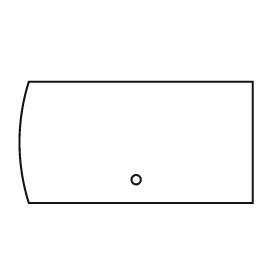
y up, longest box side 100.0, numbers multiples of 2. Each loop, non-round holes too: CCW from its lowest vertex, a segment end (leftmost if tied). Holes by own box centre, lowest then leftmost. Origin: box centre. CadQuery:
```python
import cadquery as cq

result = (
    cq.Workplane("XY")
    .moveTo(-46.0, -26.0)
    .lineTo(50.0, -26.0)
    .lineTo(50.0, 26.0)
    .lineTo(-46.0, 26.0)
    .threePointArc((-50.0, 0.0), (-46.0, -26.0))
    .close()
    .moveTo(0.0, -16.0)
    .circle(2.0)
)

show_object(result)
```